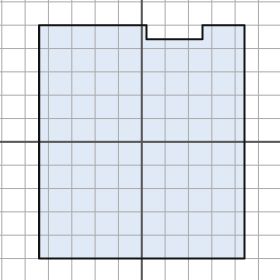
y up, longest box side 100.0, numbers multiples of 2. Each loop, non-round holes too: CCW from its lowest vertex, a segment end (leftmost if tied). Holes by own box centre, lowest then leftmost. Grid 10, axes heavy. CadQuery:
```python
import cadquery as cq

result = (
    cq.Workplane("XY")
    .moveTo(-44.0, -50.0)
    .lineTo(44.0, -50.0)
    .lineTo(44.0, 50.0)
    .lineTo(26.0, 50.0)
    .lineTo(26.0, 44.0)
    .lineTo(2.0, 44.0)
    .lineTo(2.0, 50.0)
    .lineTo(-44.0, 50.0)
    .close()
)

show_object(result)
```